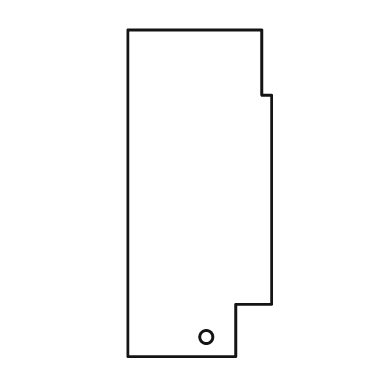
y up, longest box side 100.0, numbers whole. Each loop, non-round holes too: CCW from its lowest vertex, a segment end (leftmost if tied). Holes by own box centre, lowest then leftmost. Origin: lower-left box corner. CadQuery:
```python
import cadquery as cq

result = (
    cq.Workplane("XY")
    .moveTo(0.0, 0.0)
    .lineTo(33.0, 0.0)
    .lineTo(33.0, 16.0)
    .lineTo(44.0, 16.0)
    .lineTo(44.0, 80.0)
    .lineTo(41.0, 80.0)
    .lineTo(41.0, 100.0)
    .lineTo(0.0, 100.0)
    .close()
    .moveTo(24.0, 6.0)
    .circle(2.0)
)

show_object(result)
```